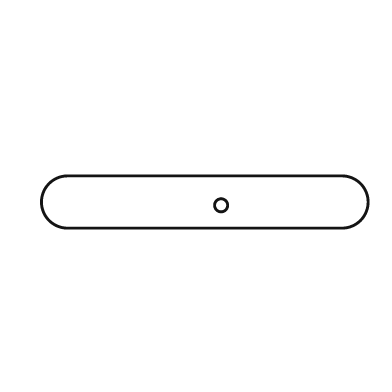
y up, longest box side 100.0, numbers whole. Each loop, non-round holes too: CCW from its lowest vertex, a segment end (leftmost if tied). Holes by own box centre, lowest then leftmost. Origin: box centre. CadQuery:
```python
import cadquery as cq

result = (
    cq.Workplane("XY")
    .moveTo(-42.0, -8.0)
    .lineTo(42.0, -8.0)
    .threePointArc((50.0, 0.0), (42.0, 8.0))
    .lineTo(-42.0, 8.0)
    .threePointArc((-50.0, 0.0), (-42.0, -8.0))
    .close()
    .moveTo(5.0, -1.0)
    .circle(2.0)
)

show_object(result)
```